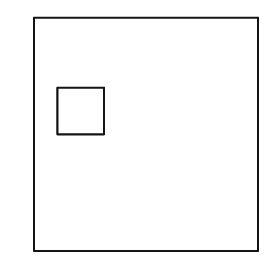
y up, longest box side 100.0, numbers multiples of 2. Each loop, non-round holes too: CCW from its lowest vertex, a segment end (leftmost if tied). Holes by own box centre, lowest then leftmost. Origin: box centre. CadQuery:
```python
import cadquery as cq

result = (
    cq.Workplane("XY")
    .moveTo(-48.0, -50.0)
    .lineTo(48.0, -50.0)
    .lineTo(48.0, 50.0)
    .lineTo(-48.0, 50.0)
    .close()
    .moveTo(-38.0, 0.0)
    .lineTo(-18.0, 0.0)
    .lineTo(-18.0, 20.0)
    .lineTo(-38.0, 20.0)
    .close()
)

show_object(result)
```